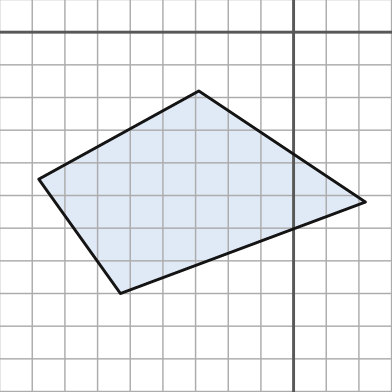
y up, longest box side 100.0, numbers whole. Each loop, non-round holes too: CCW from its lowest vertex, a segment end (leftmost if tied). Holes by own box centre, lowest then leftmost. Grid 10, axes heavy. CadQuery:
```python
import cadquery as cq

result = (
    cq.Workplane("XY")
    .moveTo(-53.0, -80.0)
    .lineTo(22.0, -52.0)
    .lineTo(-29.0, -18.0)
    .lineTo(-78.0, -45.0)
    .close()
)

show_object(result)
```